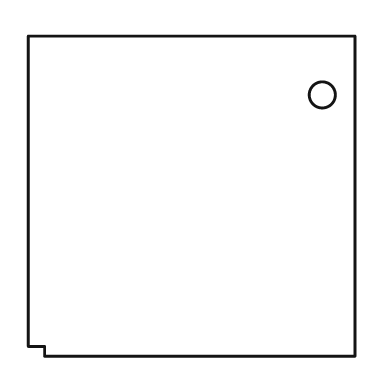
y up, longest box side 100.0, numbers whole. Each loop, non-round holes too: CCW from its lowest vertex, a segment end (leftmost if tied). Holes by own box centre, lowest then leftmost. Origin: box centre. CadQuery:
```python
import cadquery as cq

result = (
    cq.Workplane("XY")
    .moveTo(-45.0, -49.0)
    .lineTo(50.0, -49.0)
    .lineTo(50.0, 49.0)
    .lineTo(-50.0, 49.0)
    .lineTo(-50.0, -46.0)
    .lineTo(-45.0, -46.0)
    .close()
    .moveTo(40.0, 31.0)
    .circle(4.0)
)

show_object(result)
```